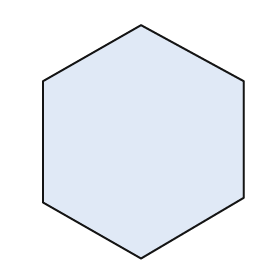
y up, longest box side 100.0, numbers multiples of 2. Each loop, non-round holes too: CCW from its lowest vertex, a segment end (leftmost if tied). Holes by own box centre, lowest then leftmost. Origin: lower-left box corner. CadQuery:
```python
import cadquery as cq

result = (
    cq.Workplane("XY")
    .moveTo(42.0, 0.0)
    .lineTo(86.0, 26.0)
    .lineTo(86.0, 76.0)
    .lineTo(42.0, 100.0)
    .lineTo(0.0, 76.0)
    .lineTo(0.0, 24.0)
    .close()
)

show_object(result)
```